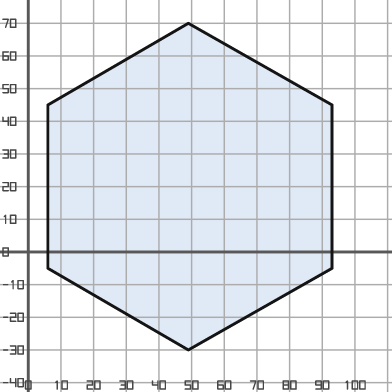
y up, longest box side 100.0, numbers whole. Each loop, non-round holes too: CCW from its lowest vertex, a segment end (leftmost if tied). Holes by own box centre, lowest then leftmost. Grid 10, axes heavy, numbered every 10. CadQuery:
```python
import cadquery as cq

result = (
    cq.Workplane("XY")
    .moveTo(49.0, -30.0)
    .lineTo(93.0, -5.0)
    .lineTo(93.0, 45.0)
    .lineTo(49.0, 70.0)
    .lineTo(6.0, 45.0)
    .lineTo(6.0, -5.0)
    .close()
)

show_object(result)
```